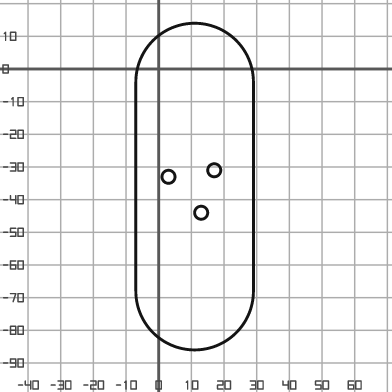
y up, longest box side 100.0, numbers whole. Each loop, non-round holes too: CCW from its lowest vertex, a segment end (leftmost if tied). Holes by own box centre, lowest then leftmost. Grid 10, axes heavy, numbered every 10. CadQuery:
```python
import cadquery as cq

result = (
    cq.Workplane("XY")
    .moveTo(-7.0, -68.0)
    .threePointArc((11.0, -86.0), (29.0, -68.0))
    .lineTo(29.0, -4.0)
    .threePointArc((11.0, 14.0), (-7.0, -4.0))
    .close()
    .moveTo(13.0, -44.0)
    .circle(2.0)
    .moveTo(3.0, -33.0)
    .circle(2.0)
    .moveTo(17.0, -31.0)
    .circle(2.0)
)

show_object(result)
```